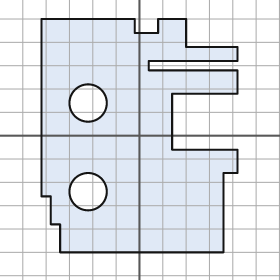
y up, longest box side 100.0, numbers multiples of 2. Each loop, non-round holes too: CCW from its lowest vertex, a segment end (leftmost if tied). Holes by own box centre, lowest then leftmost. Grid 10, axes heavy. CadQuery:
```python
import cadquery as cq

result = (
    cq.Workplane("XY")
    .moveTo(-34.0, -50.0)
    .lineTo(36.0, -50.0)
    .lineTo(36.0, -16.0)
    .lineTo(42.0, -16.0)
    .lineTo(42.0, -6.0)
    .lineTo(14.0, -6.0)
    .lineTo(14.0, 18.0)
    .lineTo(42.0, 18.0)
    .lineTo(42.0, 28.0)
    .lineTo(4.0, 28.0)
    .lineTo(4.0, 32.0)
    .lineTo(42.0, 32.0)
    .lineTo(42.0, 38.0)
    .lineTo(20.0, 38.0)
    .lineTo(20.0, 50.0)
    .lineTo(8.0, 50.0)
    .lineTo(8.0, 44.0)
    .lineTo(-2.0, 44.0)
    .lineTo(-2.0, 50.0)
    .lineTo(-42.0, 50.0)
    .lineTo(-42.0, -26.0)
    .lineTo(-38.0, -26.0)
    .lineTo(-38.0, -38.0)
    .lineTo(-34.0, -38.0)
    .close()
    .moveTo(-22.0, -24.0)
    .circle(8.0)
    .moveTo(-22.0, 14.0)
    .circle(8.0)
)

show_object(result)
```